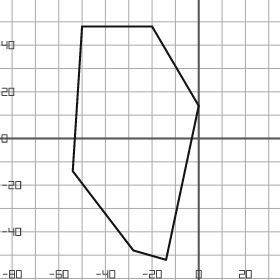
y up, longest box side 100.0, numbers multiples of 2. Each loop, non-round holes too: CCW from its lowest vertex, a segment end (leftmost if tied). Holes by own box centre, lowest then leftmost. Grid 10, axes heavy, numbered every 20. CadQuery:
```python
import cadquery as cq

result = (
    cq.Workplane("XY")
    .moveTo(-14.0, -52.0)
    .lineTo(0.0, 14.0)
    .lineTo(-20.0, 48.0)
    .lineTo(-50.0, 48.0)
    .lineTo(-54.0, -14.0)
    .lineTo(-28.0, -48.0)
    .close()
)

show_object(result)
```